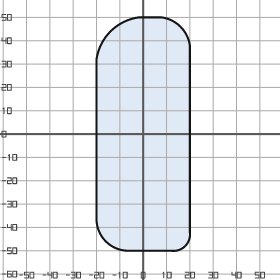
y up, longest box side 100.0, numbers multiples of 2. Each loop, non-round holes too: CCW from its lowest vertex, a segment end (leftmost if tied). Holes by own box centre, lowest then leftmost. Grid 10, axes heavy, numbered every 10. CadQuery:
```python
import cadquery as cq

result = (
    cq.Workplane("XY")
    .moveTo(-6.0, -50.0)
    .lineTo(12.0, -50.0)
    .threePointArc((18.0, -48.0), (20.0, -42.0))
    .lineTo(20.0, 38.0)
    .threePointArc((16.0, 46.0), (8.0, 50.0))
    .lineTo(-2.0, 50.0)
    .threePointArc((-14.0, 44.0), (-20.0, 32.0))
    .lineTo(-20.0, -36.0)
    .threePointArc((-16.0, -46.0), (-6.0, -50.0))
    .close()
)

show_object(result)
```